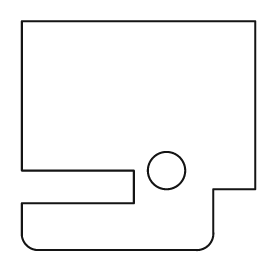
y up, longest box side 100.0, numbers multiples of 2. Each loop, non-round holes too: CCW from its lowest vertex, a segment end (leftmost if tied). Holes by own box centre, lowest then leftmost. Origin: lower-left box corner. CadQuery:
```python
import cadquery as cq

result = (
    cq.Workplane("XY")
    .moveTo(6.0, 0.0)
    .lineTo(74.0, 0.0)
    .threePointArc((80.0, 2.0), (82.0, 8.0))
    .lineTo(82.0, 26.0)
    .lineTo(100.0, 26.0)
    .lineTo(100.0, 98.0)
    .lineTo(0.0, 98.0)
    .lineTo(0.0, 34.0)
    .lineTo(48.0, 34.0)
    .lineTo(48.0, 20.0)
    .lineTo(0.0, 20.0)
    .lineTo(0.0, 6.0)
    .threePointArc((2.0, 2.0), (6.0, 0.0))
    .close()
    .moveTo(62.0, 34.0)
    .circle(8.0)
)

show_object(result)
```